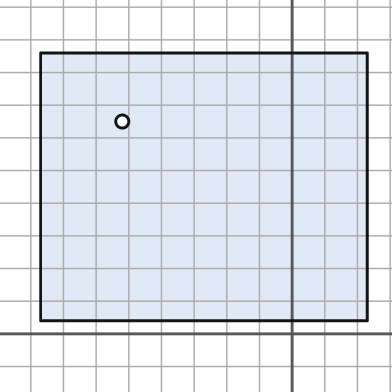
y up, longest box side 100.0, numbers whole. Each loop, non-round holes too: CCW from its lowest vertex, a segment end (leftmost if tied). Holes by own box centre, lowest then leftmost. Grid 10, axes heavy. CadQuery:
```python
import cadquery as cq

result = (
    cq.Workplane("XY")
    .moveTo(-77.0, 4.0)
    .lineTo(23.0, 4.0)
    .lineTo(23.0, 86.0)
    .lineTo(-77.0, 86.0)
    .close()
    .moveTo(-52.0, 65.0)
    .circle(2.0)
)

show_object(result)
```